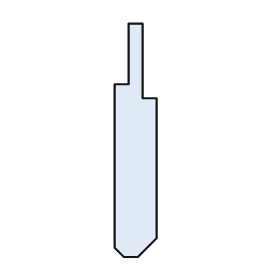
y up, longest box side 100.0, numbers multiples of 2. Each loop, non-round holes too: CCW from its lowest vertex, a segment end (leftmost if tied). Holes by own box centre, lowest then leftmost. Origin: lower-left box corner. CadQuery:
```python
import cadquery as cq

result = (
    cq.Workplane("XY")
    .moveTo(4.0, 0.0)
    .lineTo(10.0, 0.0)
    .lineTo(18.0, 8.0)
    .lineTo(18.0, 68.0)
    .lineTo(12.0, 68.0)
    .lineTo(12.0, 100.0)
    .lineTo(6.0, 100.0)
    .lineTo(6.0, 74.0)
    .lineTo(0.0, 74.0)
    .lineTo(0.0, 4.0)
    .close()
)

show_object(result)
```